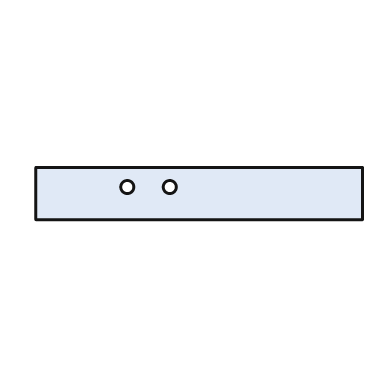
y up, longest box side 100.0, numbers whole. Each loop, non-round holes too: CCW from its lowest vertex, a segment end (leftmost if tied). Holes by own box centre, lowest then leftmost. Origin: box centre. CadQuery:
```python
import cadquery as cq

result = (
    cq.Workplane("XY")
    .moveTo(-50.0, -8.0)
    .lineTo(50.0, -8.0)
    .lineTo(50.0, 8.0)
    .lineTo(-50.0, 8.0)
    .close()
    .moveTo(-22.0, 2.0)
    .circle(2.0)
    .moveTo(-9.0, 2.0)
    .circle(2.0)
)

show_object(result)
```